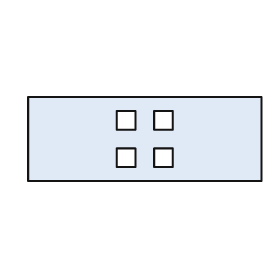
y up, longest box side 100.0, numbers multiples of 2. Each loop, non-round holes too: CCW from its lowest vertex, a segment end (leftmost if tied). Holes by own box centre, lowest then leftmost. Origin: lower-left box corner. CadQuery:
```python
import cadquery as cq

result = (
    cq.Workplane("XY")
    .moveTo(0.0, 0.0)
    .lineTo(100.0, 0.0)
    .lineTo(100.0, 36.0)
    .lineTo(0.0, 36.0)
    .close()
    .moveTo(38.0, 6.0)
    .lineTo(46.0, 6.0)
    .lineTo(46.0, 14.0)
    .lineTo(38.0, 14.0)
    .close()
    .moveTo(54.0, 6.0)
    .lineTo(62.0, 6.0)
    .lineTo(62.0, 14.0)
    .lineTo(54.0, 14.0)
    .close()
    .moveTo(38.0, 22.0)
    .lineTo(46.0, 22.0)
    .lineTo(46.0, 30.0)
    .lineTo(38.0, 30.0)
    .close()
    .moveTo(54.0, 22.0)
    .lineTo(62.0, 22.0)
    .lineTo(62.0, 30.0)
    .lineTo(54.0, 30.0)
    .close()
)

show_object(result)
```